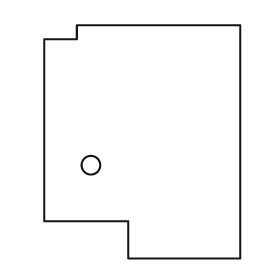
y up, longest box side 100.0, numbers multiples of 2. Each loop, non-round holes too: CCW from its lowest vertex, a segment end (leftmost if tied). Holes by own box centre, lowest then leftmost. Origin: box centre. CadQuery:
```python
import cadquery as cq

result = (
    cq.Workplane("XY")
    .moveTo(-6.0, -50.0)
    .lineTo(42.0, -50.0)
    .lineTo(42.0, 50.0)
    .lineTo(-28.0, 50.0)
    .lineTo(-28.0, 44.0)
    .lineTo(-42.0, 44.0)
    .lineTo(-42.0, -34.0)
    .lineTo(-6.0, -34.0)
    .close()
    .moveTo(-22.0, -10.0)
    .circle(4.0)
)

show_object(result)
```